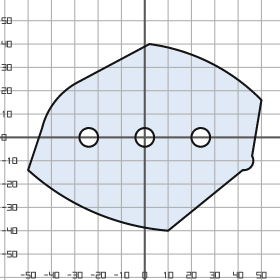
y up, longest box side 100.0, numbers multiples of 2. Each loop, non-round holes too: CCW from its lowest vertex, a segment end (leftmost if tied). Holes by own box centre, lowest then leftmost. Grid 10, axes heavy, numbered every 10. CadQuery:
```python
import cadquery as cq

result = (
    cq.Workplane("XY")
    .moveTo(10.0, -40.0)
    .lineTo(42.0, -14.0)
    .threePointArc((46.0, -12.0), (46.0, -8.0))
    .lineTo(50.0, 16.0)
    .threePointArc((28.0, 32.0), (2.0, 40.0))
    .lineTo(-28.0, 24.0)
    .threePointArc((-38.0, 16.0), (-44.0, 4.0))
    .lineTo(-50.0, -14.0)
    .threePointArc((-22.0, -32.0), (10.0, -40.0))
    .close()
    .moveTo(-24.0, 0.0)
    .circle(4.0)
    .moveTo(0.0, 0.0)
    .circle(4.0)
    .moveTo(24.0, 0.0)
    .circle(4.0)
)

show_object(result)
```